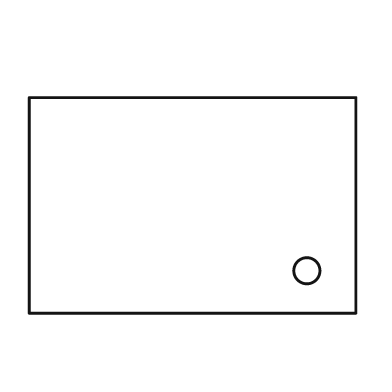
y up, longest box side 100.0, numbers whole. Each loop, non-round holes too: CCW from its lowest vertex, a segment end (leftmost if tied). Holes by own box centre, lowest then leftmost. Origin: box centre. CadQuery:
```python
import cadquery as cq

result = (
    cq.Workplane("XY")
    .moveTo(-50.0, -33.0)
    .lineTo(50.0, -33.0)
    .lineTo(50.0, 33.0)
    .lineTo(-50.0, 33.0)
    .close()
    .moveTo(35.0, -20.0)
    .circle(4.0)
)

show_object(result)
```